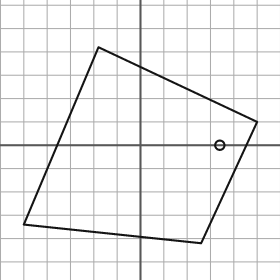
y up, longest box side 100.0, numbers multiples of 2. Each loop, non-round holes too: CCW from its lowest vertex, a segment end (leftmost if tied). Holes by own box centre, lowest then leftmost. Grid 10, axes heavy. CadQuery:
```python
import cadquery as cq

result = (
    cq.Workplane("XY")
    .moveTo(26.0, -42.0)
    .lineTo(50.0, 10.0)
    .lineTo(-18.0, 42.0)
    .lineTo(-50.0, -34.0)
    .close()
    .moveTo(34.0, 0.0)
    .circle(2.0)
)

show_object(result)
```